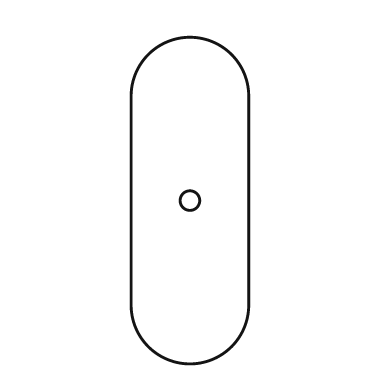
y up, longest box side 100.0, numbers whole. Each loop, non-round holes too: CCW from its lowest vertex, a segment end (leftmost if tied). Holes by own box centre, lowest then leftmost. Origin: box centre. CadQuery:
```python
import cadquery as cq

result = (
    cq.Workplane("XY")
    .moveTo(-18.0, -32.0)
    .threePointArc((0.0, -50.0), (18.0, -32.0))
    .lineTo(18.0, 32.0)
    .threePointArc((0.0, 50.0), (-18.0, 32.0))
    .close()
    .moveTo(0.0, 0.0)
    .circle(3.0)
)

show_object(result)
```